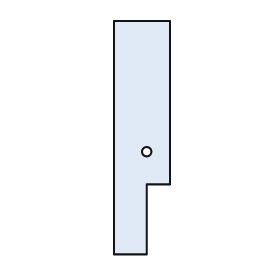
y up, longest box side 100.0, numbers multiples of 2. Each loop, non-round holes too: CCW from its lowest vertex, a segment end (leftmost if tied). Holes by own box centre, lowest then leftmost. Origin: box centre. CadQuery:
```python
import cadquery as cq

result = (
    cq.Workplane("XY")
    .moveTo(-12.0, -50.0)
    .lineTo(2.0, -50.0)
    .lineTo(2.0, -20.0)
    .lineTo(12.0, -20.0)
    .lineTo(12.0, 50.0)
    .lineTo(-12.0, 50.0)
    .close()
    .moveTo(2.0, -6.0)
    .circle(2.0)
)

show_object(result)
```